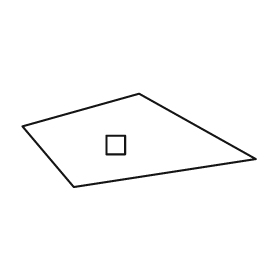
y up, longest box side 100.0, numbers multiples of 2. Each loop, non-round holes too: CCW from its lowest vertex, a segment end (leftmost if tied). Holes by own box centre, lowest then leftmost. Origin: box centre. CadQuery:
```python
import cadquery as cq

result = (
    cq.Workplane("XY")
    .moveTo(-28.0, -20.0)
    .lineTo(50.0, -8.0)
    .lineTo(0.0, 20.0)
    .lineTo(-50.0, 6.0)
    .close()
    .moveTo(-14.0, -6.0)
    .lineTo(-6.0, -6.0)
    .lineTo(-6.0, 2.0)
    .lineTo(-14.0, 2.0)
    .close()
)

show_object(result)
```